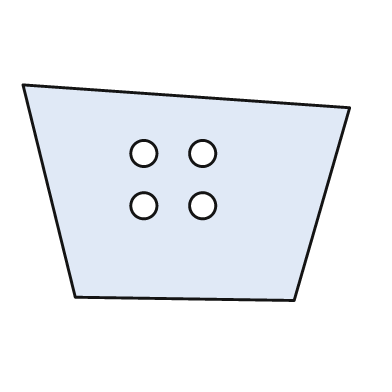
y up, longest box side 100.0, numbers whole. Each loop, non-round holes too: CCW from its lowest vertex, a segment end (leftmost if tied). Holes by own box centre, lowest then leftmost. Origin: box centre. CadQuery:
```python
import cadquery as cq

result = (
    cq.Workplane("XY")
    .moveTo(33.0, -33.0)
    .lineTo(50.0, 26.0)
    .lineTo(-50.0, 33.0)
    .lineTo(-34.0, -32.0)
    .close()
    .moveTo(-13.0, -4.0)
    .circle(4.0)
    .moveTo(5.0, -4.0)
    .circle(4.0)
    .moveTo(-13.0, 12.0)
    .circle(4.0)
    .moveTo(5.0, 12.0)
    .circle(4.0)
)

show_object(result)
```